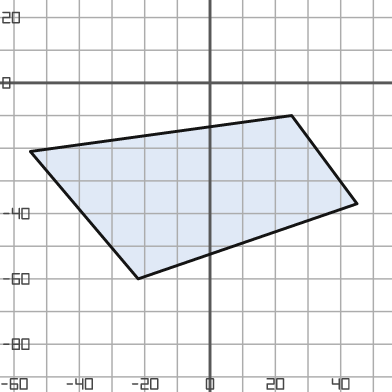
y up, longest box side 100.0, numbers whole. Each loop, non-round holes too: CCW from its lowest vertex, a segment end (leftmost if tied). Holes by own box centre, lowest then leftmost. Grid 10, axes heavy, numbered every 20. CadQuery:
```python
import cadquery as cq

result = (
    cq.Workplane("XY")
    .moveTo(-22.0, -60.0)
    .lineTo(45.0, -37.0)
    .lineTo(25.0, -10.0)
    .lineTo(-55.0, -21.0)
    .close()
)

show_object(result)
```